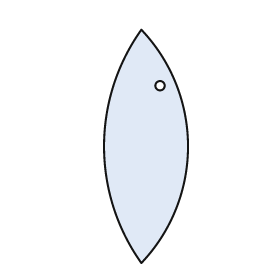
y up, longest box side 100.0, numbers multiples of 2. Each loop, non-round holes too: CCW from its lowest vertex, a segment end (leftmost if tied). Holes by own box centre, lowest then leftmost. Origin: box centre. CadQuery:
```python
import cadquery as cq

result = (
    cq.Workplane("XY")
    .moveTo(-2.0, -50.0)
    .threePointArc((18.0, 0.0), (-2.0, 50.0))
    .threePointArc((-18.0, 0.0), (-2.0, -50.0))
    .close()
    .moveTo(6.0, 26.0)
    .circle(2.0)
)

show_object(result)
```